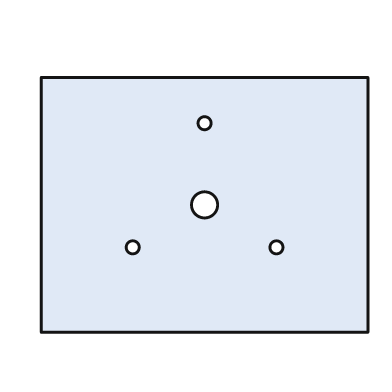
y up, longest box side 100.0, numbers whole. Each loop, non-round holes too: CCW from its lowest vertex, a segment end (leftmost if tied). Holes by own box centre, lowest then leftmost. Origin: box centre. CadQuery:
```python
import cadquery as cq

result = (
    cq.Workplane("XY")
    .moveTo(-50.0, -39.0)
    .lineTo(50.0, -39.0)
    .lineTo(50.0, 39.0)
    .lineTo(-50.0, 39.0)
    .close()
    .moveTo(-22.0, -13.0)
    .circle(2.0)
    .moveTo(22.0, -13.0)
    .circle(2.0)
    .moveTo(0.0, 0.0)
    .circle(4.0)
    .moveTo(0.0, 25.0)
    .circle(2.0)
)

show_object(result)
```